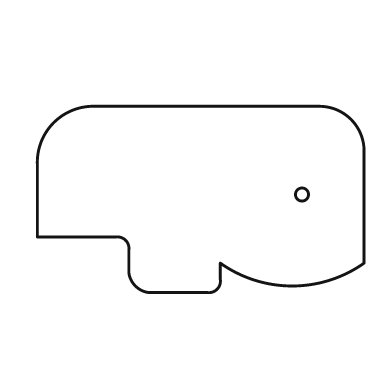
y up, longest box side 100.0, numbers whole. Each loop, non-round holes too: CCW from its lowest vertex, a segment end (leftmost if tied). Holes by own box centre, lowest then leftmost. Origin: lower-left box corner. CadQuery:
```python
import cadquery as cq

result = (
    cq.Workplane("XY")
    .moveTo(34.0, 0.0)
    .lineTo(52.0, 0.0)
    .threePointArc((55.0, 1.0), (56.0, 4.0))
    .lineTo(56.0, 9.0)
    .threePointArc((78.0, 2.0), (100.0, 9.0))
    .lineTo(100.0, 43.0)
    .threePointArc((96.0, 53.0), (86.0, 57.0))
    .lineTo(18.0, 57.0)
    .threePointArc((5.0, 52.0), (0.0, 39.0))
    .lineTo(0.0, 17.0)
    .lineTo(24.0, 17.0)
    .threePointArc((27.0, 16.0), (28.0, 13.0))
    .lineTo(28.0, 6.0)
    .threePointArc((30.0, 2.0), (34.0, 0.0))
    .close()
    .moveTo(81.0, 30.0)
    .circle(2.0)
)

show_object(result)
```